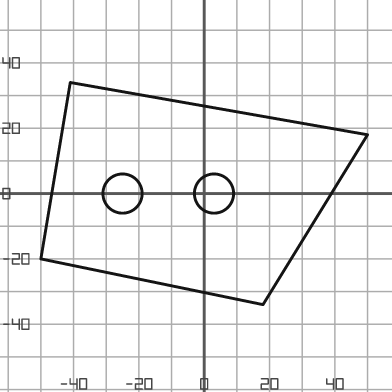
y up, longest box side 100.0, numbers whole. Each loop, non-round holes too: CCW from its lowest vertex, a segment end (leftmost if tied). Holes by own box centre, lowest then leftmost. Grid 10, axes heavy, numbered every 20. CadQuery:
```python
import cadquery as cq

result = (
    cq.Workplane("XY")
    .moveTo(18.0, -34.0)
    .lineTo(50.0, 18.0)
    .lineTo(-41.0, 34.0)
    .lineTo(-50.0, -20.0)
    .close()
    .moveTo(-25.0, 0.0)
    .circle(6.0)
    .moveTo(3.0, 0.0)
    .circle(6.0)
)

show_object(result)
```